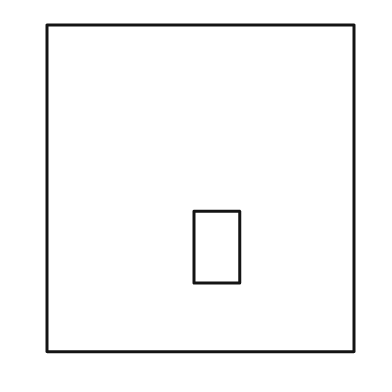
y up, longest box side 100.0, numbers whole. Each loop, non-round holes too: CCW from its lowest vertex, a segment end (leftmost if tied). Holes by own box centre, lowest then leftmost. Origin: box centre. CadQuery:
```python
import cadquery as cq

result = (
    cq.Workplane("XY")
    .moveTo(-47.0, -50.0)
    .lineTo(47.0, -50.0)
    .lineTo(47.0, 50.0)
    .lineTo(-47.0, 50.0)
    .close()
    .moveTo(-2.0, -29.0)
    .lineTo(12.0, -29.0)
    .lineTo(12.0, -7.0)
    .lineTo(-2.0, -7.0)
    .close()
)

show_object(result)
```